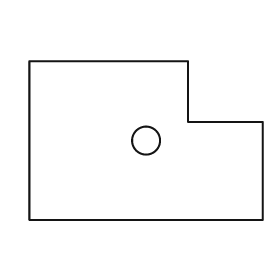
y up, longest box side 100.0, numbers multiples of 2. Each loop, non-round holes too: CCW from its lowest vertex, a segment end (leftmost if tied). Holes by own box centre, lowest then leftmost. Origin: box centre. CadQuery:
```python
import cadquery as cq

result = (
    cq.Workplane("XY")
    .moveTo(-50.0, -34.0)
    .lineTo(50.0, -34.0)
    .lineTo(50.0, 8.0)
    .lineTo(18.0, 8.0)
    .lineTo(18.0, 34.0)
    .lineTo(-50.0, 34.0)
    .close()
    .moveTo(0.0, 0.0)
    .circle(6.0)
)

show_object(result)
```